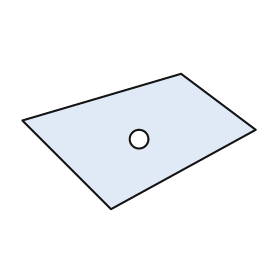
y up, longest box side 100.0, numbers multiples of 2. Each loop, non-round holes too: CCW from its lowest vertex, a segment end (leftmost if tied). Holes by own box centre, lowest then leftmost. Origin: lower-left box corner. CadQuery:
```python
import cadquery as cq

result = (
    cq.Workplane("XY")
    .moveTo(38.0, 0.0)
    .lineTo(100.0, 34.0)
    .lineTo(68.0, 58.0)
    .lineTo(0.0, 38.0)
    .close()
    .moveTo(50.0, 30.0)
    .circle(4.0)
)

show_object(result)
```